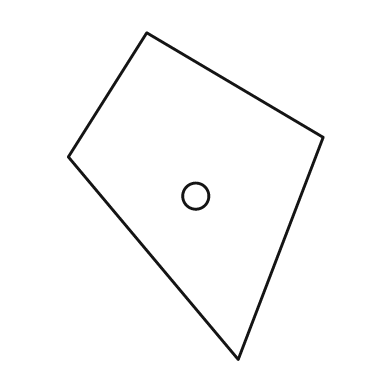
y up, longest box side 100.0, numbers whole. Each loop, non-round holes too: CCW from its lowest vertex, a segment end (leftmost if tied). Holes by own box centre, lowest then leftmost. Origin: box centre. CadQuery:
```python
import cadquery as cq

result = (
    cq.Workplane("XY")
    .moveTo(13.0, -50.0)
    .lineTo(39.0, 18.0)
    .lineTo(-15.0, 50.0)
    .lineTo(-39.0, 12.0)
    .close()
    .moveTo(0.0, 0.0)
    .circle(4.0)
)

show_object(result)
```